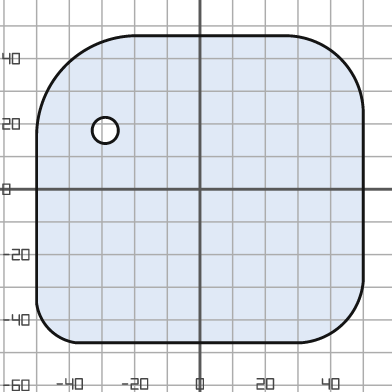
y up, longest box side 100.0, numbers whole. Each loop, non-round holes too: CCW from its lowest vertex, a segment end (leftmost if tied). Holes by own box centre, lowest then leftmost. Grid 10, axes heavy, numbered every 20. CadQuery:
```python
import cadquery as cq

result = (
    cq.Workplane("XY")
    .moveTo(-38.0, -47.0)
    .lineTo(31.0, -47.0)
    .threePointArc((44.0, -41.0), (50.0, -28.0))
    .lineTo(50.0, 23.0)
    .threePointArc((43.0, 40.0), (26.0, 47.0))
    .lineTo(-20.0, 47.0)
    .threePointArc((-41.0, 38.0), (-50.0, 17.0))
    .lineTo(-50.0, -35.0)
    .threePointArc((-46.0, -43.0), (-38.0, -47.0))
    .close()
    .moveTo(-29.0, 18.0)
    .circle(4.0)
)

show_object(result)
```